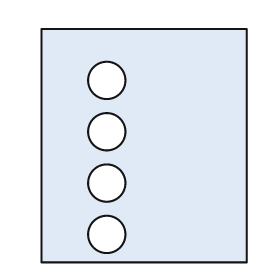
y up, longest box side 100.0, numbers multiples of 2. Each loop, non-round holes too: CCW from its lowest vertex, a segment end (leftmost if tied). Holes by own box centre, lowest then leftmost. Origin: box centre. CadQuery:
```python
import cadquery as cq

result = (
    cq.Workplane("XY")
    .moveTo(-44.0, -50.0)
    .lineTo(44.0, -50.0)
    .lineTo(44.0, 50.0)
    .lineTo(-44.0, 50.0)
    .close()
    .moveTo(-16.0, -38.0)
    .circle(8.0)
    .moveTo(-16.0, -16.0)
    .circle(8.0)
    .moveTo(-16.0, 6.0)
    .circle(8.0)
    .moveTo(-16.0, 28.0)
    .circle(8.0)
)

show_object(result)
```